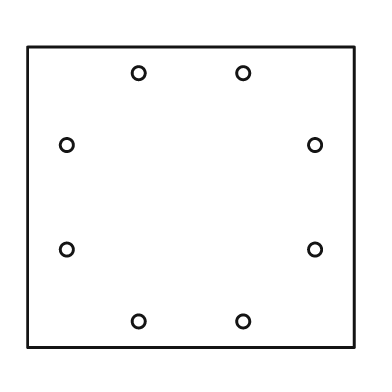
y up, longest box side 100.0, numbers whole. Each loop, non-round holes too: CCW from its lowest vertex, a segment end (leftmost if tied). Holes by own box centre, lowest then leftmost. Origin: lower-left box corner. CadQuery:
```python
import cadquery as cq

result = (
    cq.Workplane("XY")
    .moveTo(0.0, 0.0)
    .lineTo(100.0, 0.0)
    .lineTo(100.0, 92.0)
    .lineTo(0.0, 92.0)
    .close()
    .moveTo(34.0, 8.0)
    .circle(2.0)
    .moveTo(66.0, 8.0)
    .circle(2.0)
    .moveTo(12.0, 30.0)
    .circle(2.0)
    .moveTo(88.0, 30.0)
    .circle(2.0)
    .moveTo(12.0, 62.0)
    .circle(2.0)
    .moveTo(88.0, 62.0)
    .circle(2.0)
    .moveTo(34.0, 84.0)
    .circle(2.0)
    .moveTo(66.0, 84.0)
    .circle(2.0)
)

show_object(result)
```